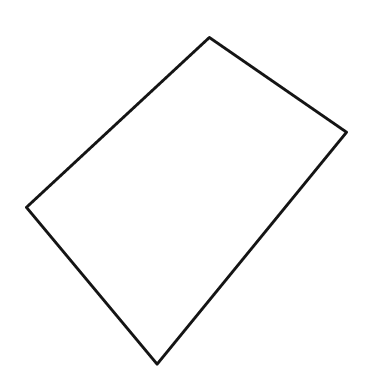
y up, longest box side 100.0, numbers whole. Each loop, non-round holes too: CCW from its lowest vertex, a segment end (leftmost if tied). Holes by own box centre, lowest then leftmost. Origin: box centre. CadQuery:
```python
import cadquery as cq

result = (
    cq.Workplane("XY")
    .moveTo(-9.0, -50.0)
    .lineTo(49.0, 21.0)
    .lineTo(7.0, 50.0)
    .lineTo(-49.0, -2.0)
    .close()
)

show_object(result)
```